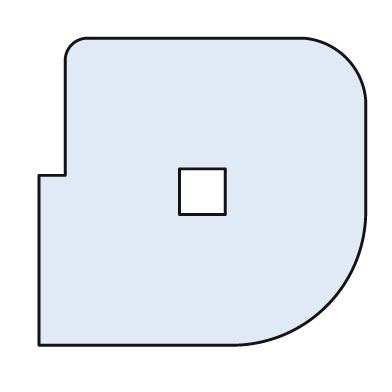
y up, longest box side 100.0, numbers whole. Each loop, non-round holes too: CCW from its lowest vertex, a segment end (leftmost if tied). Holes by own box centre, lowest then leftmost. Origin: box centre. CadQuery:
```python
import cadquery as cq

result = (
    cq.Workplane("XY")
    .moveTo(-50.0, -47.0)
    .lineTo(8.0, -47.0)
    .threePointArc((38.0, -35.0), (50.0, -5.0))
    .lineTo(50.0, 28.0)
    .threePointArc((44.0, 41.0), (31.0, 47.0))
    .lineTo(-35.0, 47.0)
    .threePointArc((-40.0, 45.0), (-42.0, 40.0))
    .lineTo(-42.0, 5.0)
    .lineTo(-50.0, 5.0)
    .close()
    .moveTo(-7.0, -7.0)
    .lineTo(7.0, -7.0)
    .lineTo(7.0, 7.0)
    .lineTo(-7.0, 7.0)
    .close()
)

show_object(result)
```